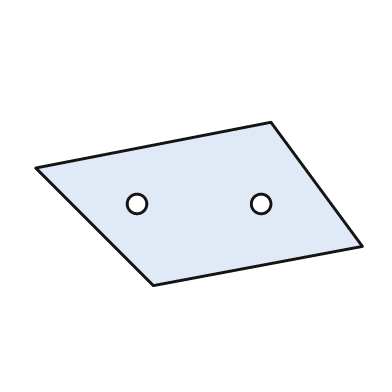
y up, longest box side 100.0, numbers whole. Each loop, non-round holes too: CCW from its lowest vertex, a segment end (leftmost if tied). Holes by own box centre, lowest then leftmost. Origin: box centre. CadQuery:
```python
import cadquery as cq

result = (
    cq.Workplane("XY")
    .moveTo(-14.0, -25.0)
    .lineTo(50.0, -13.0)
    .lineTo(22.0, 25.0)
    .lineTo(-50.0, 11.0)
    .close()
    .moveTo(-19.0, 0.0)
    .circle(3.0)
    .moveTo(19.0, 0.0)
    .circle(3.0)
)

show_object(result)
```